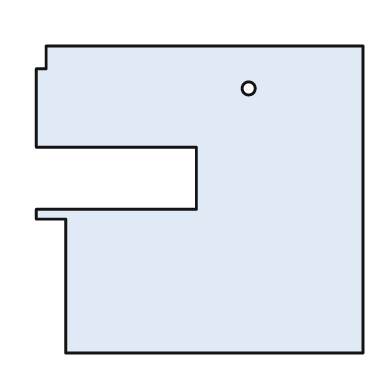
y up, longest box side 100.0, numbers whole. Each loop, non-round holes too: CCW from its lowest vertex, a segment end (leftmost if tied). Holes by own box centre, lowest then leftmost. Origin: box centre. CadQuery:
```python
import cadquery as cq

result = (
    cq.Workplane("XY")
    .moveTo(-41.0, -47.0)
    .lineTo(50.0, -47.0)
    .lineTo(50.0, 47.0)
    .lineTo(-47.0, 47.0)
    .lineTo(-47.0, 40.0)
    .lineTo(-50.0, 40.0)
    .lineTo(-50.0, 16.0)
    .lineTo(-1.0, 16.0)
    .lineTo(-1.0, -3.0)
    .lineTo(-50.0, -3.0)
    .lineTo(-50.0, -6.0)
    .lineTo(-41.0, -6.0)
    .close()
    .moveTo(15.0, 34.0)
    .circle(2.0)
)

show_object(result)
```